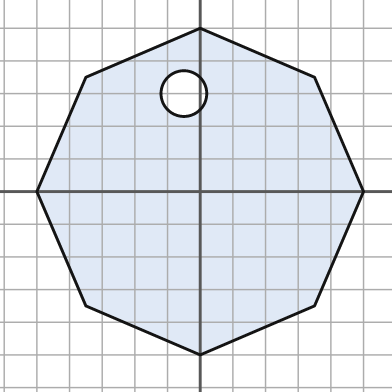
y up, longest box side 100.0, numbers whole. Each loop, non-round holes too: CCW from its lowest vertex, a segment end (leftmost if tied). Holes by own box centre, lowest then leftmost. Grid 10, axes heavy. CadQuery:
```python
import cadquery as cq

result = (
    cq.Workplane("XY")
    .moveTo(0.0, -50.0)
    .lineTo(35.0, -35.0)
    .lineTo(50.0, 0.0)
    .lineTo(35.0, 35.0)
    .lineTo(0.0, 50.0)
    .lineTo(-35.0, 35.0)
    .lineTo(-50.0, 0.0)
    .lineTo(-35.0, -35.0)
    .close()
    .moveTo(-5.0, 30.0)
    .circle(7.0)
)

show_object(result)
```